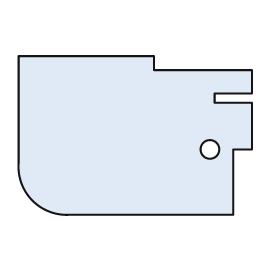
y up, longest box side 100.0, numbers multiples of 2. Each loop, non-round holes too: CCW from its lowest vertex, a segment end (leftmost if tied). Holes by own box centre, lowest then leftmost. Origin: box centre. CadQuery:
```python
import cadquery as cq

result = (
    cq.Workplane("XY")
    .moveTo(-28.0, -34.0)
    .lineTo(42.0, -34.0)
    .lineTo(42.0, -6.0)
    .lineTo(50.0, -6.0)
    .lineTo(50.0, 14.0)
    .lineTo(34.0, 14.0)
    .lineTo(34.0, 18.0)
    .lineTo(50.0, 18.0)
    .lineTo(50.0, 28.0)
    .lineTo(8.0, 28.0)
    .lineTo(8.0, 34.0)
    .lineTo(-50.0, 34.0)
    .lineTo(-50.0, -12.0)
    .threePointArc((-44.0, -28.0), (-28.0, -34.0))
    .close()
    .moveTo(32.0, -6.0)
    .circle(4.0)
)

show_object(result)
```